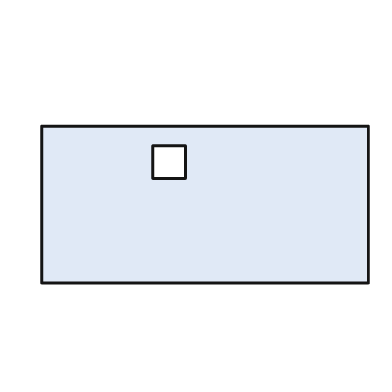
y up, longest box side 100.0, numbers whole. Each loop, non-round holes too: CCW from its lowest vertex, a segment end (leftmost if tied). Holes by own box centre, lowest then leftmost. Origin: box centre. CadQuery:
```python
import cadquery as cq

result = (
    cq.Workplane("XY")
    .moveTo(-50.0, -24.0)
    .lineTo(50.0, -24.0)
    .lineTo(50.0, 24.0)
    .lineTo(-50.0, 24.0)
    .close()
    .moveTo(-16.0, 8.0)
    .lineTo(-6.0, 8.0)
    .lineTo(-6.0, 18.0)
    .lineTo(-16.0, 18.0)
    .close()
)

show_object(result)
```